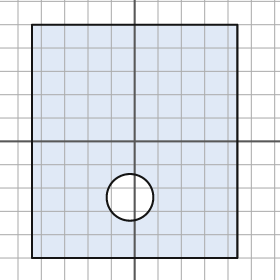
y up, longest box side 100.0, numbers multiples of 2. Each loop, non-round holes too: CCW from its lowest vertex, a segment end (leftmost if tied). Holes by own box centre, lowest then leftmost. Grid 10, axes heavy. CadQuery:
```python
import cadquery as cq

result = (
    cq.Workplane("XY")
    .moveTo(-44.0, -50.0)
    .lineTo(44.0, -50.0)
    .lineTo(44.0, 50.0)
    .lineTo(-44.0, 50.0)
    .close()
    .moveTo(-2.0, -24.0)
    .circle(10.0)
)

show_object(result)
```